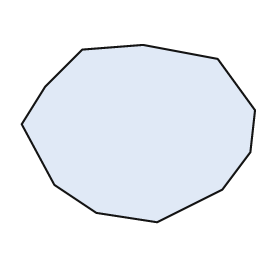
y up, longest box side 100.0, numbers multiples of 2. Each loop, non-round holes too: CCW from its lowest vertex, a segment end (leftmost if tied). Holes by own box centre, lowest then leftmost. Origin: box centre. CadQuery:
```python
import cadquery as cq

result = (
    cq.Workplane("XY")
    .moveTo(8.0, -38.0)
    .lineTo(36.0, -24.0)
    .lineTo(48.0, -8.0)
    .lineTo(50.0, 10.0)
    .lineTo(34.0, 32.0)
    .lineTo(2.0, 38.0)
    .lineTo(-24.0, 36.0)
    .lineTo(-40.0, 20.0)
    .lineTo(-50.0, 4.0)
    .lineTo(-36.0, -22.0)
    .lineTo(-18.0, -34.0)
    .close()
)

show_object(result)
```